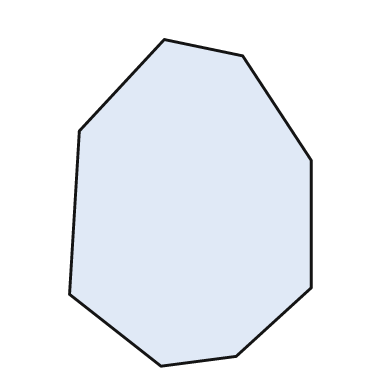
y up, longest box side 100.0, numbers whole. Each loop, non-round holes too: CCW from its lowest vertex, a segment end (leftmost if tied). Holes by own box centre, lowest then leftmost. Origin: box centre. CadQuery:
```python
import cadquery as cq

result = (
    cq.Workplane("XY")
    .moveTo(-9.0, -50.0)
    .lineTo(14.0, -47.0)
    .lineTo(37.0, -26.0)
    .lineTo(37.0, 13.0)
    .lineTo(16.0, 45.0)
    .lineTo(-8.0, 50.0)
    .lineTo(-34.0, 22.0)
    .lineTo(-37.0, -28.0)
    .close()
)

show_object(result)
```